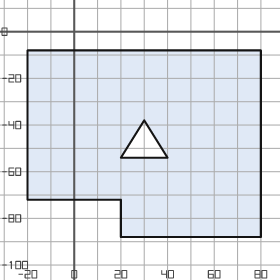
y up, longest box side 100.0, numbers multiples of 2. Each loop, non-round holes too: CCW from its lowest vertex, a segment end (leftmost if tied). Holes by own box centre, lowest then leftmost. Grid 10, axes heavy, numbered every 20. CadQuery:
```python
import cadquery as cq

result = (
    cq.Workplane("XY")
    .moveTo(20.0, -88.0)
    .lineTo(80.0, -88.0)
    .lineTo(80.0, -8.0)
    .lineTo(-20.0, -8.0)
    .lineTo(-20.0, -72.0)
    .lineTo(20.0, -72.0)
    .close()
    .moveTo(20.0, -54.0)
    .lineTo(40.0, -54.0)
    .lineTo(30.0, -38.0)
    .close()
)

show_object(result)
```